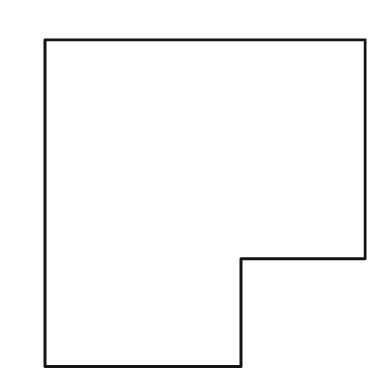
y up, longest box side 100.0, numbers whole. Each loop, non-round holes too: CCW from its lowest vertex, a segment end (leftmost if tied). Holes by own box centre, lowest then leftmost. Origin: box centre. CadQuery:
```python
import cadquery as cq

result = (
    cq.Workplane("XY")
    .moveTo(-49.0, -50.0)
    .lineTo(11.0, -50.0)
    .lineTo(11.0, -17.0)
    .lineTo(49.0, -17.0)
    .lineTo(49.0, 50.0)
    .lineTo(-49.0, 50.0)
    .close()
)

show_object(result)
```